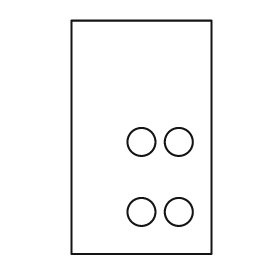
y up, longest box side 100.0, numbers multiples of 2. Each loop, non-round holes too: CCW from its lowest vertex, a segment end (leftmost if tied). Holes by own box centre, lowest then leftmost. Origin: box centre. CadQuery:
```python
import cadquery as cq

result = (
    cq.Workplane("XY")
    .moveTo(-30.0, -50.0)
    .lineTo(30.0, -50.0)
    .lineTo(30.0, 50.0)
    .lineTo(-30.0, 50.0)
    .close()
    .moveTo(0.0, -32.0)
    .circle(6.0)
    .moveTo(16.0, -32.0)
    .circle(6.0)
    .moveTo(0.0, -2.0)
    .circle(6.0)
    .moveTo(16.0, -2.0)
    .circle(6.0)
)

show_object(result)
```